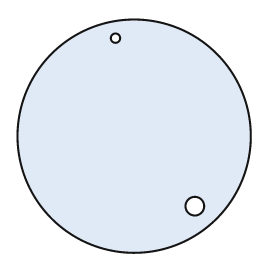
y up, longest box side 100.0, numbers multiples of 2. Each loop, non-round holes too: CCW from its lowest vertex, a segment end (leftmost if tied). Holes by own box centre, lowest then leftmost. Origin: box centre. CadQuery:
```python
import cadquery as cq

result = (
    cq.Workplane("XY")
    .moveTo(0.0, 0.0)
    .circle(50.0)
    .moveTo(26.0, -30.0)
    .circle(4.0)
    .moveTo(-8.0, 42.0)
    .circle(2.0)
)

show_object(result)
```